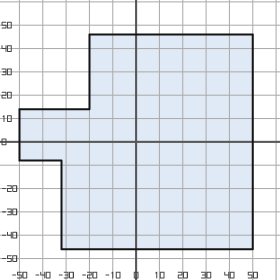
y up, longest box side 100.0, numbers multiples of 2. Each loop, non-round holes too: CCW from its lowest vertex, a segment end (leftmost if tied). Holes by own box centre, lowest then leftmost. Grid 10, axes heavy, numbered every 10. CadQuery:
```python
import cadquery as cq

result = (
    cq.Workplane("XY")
    .moveTo(-32.0, -46.0)
    .lineTo(50.0, -46.0)
    .lineTo(50.0, 46.0)
    .lineTo(-20.0, 46.0)
    .lineTo(-20.0, 14.0)
    .lineTo(-50.0, 14.0)
    .lineTo(-50.0, -8.0)
    .lineTo(-32.0, -8.0)
    .close()
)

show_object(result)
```